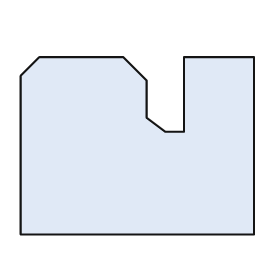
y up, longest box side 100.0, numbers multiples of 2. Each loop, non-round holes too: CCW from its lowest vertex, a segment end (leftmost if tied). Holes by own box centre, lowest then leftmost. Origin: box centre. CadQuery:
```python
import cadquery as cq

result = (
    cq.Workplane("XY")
    .moveTo(-50.0, -38.0)
    .lineTo(50.0, -38.0)
    .lineTo(50.0, 38.0)
    .lineTo(20.0, 38.0)
    .lineTo(20.0, 6.0)
    .lineTo(12.0, 6.0)
    .lineTo(4.0, 12.0)
    .lineTo(4.0, 28.0)
    .lineTo(-6.0, 38.0)
    .lineTo(-42.0, 38.0)
    .lineTo(-50.0, 30.0)
    .close()
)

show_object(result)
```